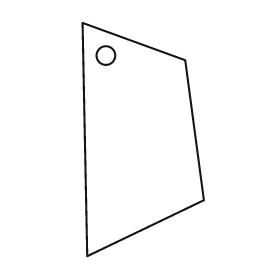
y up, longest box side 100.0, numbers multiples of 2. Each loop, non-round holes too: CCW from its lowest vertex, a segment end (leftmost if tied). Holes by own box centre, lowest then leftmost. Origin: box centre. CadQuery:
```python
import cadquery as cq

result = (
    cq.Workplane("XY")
    .moveTo(-24.0, -50.0)
    .lineTo(26.0, -26.0)
    .lineTo(18.0, 34.0)
    .lineTo(-26.0, 50.0)
    .close()
    .moveTo(-16.0, 36.0)
    .circle(4.0)
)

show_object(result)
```